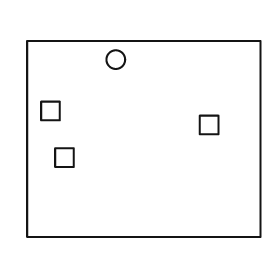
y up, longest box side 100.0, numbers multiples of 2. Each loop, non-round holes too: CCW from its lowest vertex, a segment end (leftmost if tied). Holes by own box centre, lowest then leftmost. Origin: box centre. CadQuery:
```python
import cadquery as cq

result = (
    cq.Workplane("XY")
    .moveTo(-50.0, -42.0)
    .lineTo(50.0, -42.0)
    .lineTo(50.0, 42.0)
    .lineTo(-50.0, 42.0)
    .close()
    .moveTo(-38.0, -12.0)
    .lineTo(-30.0, -12.0)
    .lineTo(-30.0, -4.0)
    .lineTo(-38.0, -4.0)
    .close()
    .moveTo(24.0, 2.0)
    .lineTo(32.0, 2.0)
    .lineTo(32.0, 10.0)
    .lineTo(24.0, 10.0)
    .close()
    .moveTo(-44.0, 8.0)
    .lineTo(-36.0, 8.0)
    .lineTo(-36.0, 16.0)
    .lineTo(-44.0, 16.0)
    .close()
    .moveTo(-12.0, 34.0)
    .circle(4.0)
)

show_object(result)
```